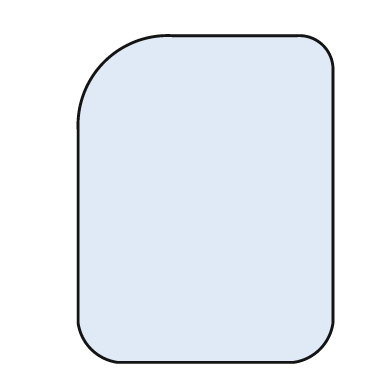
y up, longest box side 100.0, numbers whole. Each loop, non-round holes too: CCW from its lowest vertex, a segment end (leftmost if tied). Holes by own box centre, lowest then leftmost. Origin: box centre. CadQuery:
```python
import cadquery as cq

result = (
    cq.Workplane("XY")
    .moveTo(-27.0, -50.0)
    .lineTo(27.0, -50.0)
    .threePointArc((35.0, -46.0), (39.0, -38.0))
    .lineTo(39.0, 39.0)
    .threePointArc((36.0, 47.0), (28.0, 50.0))
    .lineTo(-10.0, 50.0)
    .threePointArc((-31.0, 42.0), (-39.0, 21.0))
    .lineTo(-39.0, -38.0)
    .threePointArc((-35.0, -46.0), (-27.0, -50.0))
    .close()
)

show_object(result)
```